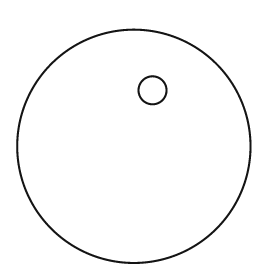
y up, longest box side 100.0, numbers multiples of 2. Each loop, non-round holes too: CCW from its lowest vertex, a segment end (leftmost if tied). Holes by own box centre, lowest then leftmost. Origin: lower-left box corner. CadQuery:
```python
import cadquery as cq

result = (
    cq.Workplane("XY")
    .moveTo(50.0, 50.0)
    .circle(50.0)
    .moveTo(58.0, 74.0)
    .circle(6.0)
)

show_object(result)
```